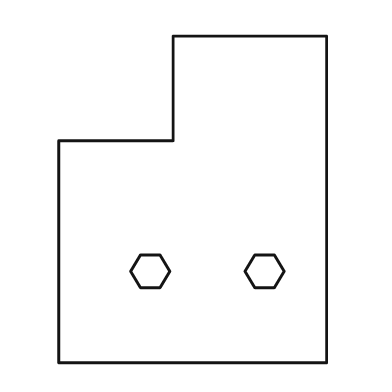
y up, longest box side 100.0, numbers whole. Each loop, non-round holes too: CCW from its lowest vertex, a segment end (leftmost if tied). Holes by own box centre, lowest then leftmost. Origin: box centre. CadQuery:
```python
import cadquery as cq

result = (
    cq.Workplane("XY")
    .moveTo(-41.0, -50.0)
    .lineTo(41.0, -50.0)
    .lineTo(41.0, 50.0)
    .lineTo(-6.0, 50.0)
    .lineTo(-6.0, 18.0)
    .lineTo(-41.0, 18.0)
    .close()
    .moveTo(-16.0, -27.0)
    .lineTo(-10.0, -27.0)
    .lineTo(-7.0, -22.0)
    .lineTo(-10.0, -17.0)
    .lineTo(-16.0, -17.0)
    .lineTo(-19.0, -22.0)
    .close()
    .moveTo(19.0, -27.0)
    .lineTo(25.0, -27.0)
    .lineTo(28.0, -22.0)
    .lineTo(25.0, -17.0)
    .lineTo(19.0, -17.0)
    .lineTo(16.0, -22.0)
    .close()
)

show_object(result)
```